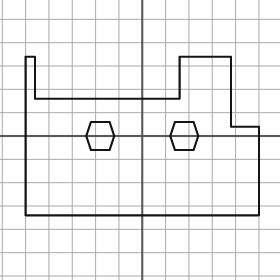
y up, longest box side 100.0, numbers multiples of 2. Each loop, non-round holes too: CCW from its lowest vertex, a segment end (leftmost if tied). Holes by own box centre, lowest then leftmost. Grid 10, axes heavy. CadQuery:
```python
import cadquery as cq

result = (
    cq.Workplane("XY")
    .moveTo(-50.0, -34.0)
    .lineTo(50.0, -34.0)
    .lineTo(50.0, 4.0)
    .lineTo(38.0, 4.0)
    .lineTo(38.0, 34.0)
    .lineTo(16.0, 34.0)
    .lineTo(16.0, 16.0)
    .lineTo(-46.0, 16.0)
    .lineTo(-46.0, 34.0)
    .lineTo(-50.0, 34.0)
    .close()
    .moveTo(-22.0, -6.0)
    .lineTo(-14.0, -6.0)
    .lineTo(-12.0, 0.0)
    .lineTo(-14.0, 6.0)
    .lineTo(-22.0, 6.0)
    .lineTo(-24.0, 0.0)
    .close()
    .moveTo(14.0, -6.0)
    .lineTo(22.0, -6.0)
    .lineTo(24.0, 0.0)
    .lineTo(22.0, 6.0)
    .lineTo(14.0, 6.0)
    .lineTo(12.0, 0.0)
    .close()
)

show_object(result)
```